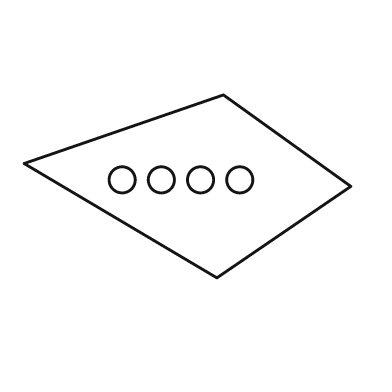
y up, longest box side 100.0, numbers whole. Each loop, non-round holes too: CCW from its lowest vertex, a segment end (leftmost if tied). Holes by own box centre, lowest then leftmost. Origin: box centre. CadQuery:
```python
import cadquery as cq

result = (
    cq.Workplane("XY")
    .moveTo(9.0, -28.0)
    .lineTo(50.0, 0.0)
    .lineTo(11.0, 28.0)
    .lineTo(-50.0, 7.0)
    .close()
    .moveTo(-20.0, 2.0)
    .circle(4.0)
    .moveTo(-8.0, 2.0)
    .circle(4.0)
    .moveTo(4.0, 2.0)
    .circle(4.0)
    .moveTo(16.0, 2.0)
    .circle(4.0)
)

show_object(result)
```